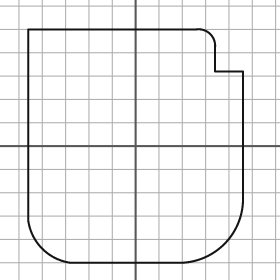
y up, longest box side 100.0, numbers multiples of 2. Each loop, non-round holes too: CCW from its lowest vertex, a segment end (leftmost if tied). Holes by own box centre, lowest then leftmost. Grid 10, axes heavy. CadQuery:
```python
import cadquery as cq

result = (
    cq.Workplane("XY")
    .moveTo(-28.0, -50.0)
    .lineTo(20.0, -50.0)
    .threePointArc((38.0, -42.0), (46.0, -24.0))
    .lineTo(46.0, 32.0)
    .lineTo(34.0, 32.0)
    .lineTo(34.0, 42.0)
    .threePointArc((32.0, 48.0), (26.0, 50.0))
    .lineTo(-46.0, 50.0)
    .lineTo(-46.0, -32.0)
    .threePointArc((-40.0, -44.0), (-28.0, -50.0))
    .close()
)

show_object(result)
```